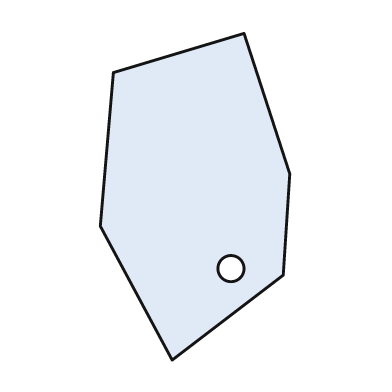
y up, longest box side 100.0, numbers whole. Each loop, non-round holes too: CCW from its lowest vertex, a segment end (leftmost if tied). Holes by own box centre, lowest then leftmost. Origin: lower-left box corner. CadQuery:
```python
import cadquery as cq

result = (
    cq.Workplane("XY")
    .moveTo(22.0, 0.0)
    .lineTo(56.0, 26.0)
    .lineTo(58.0, 57.0)
    .lineTo(44.0, 100.0)
    .lineTo(4.0, 88.0)
    .lineTo(0.0, 41.0)
    .close()
    .moveTo(40.0, 28.0)
    .circle(4.0)
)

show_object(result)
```